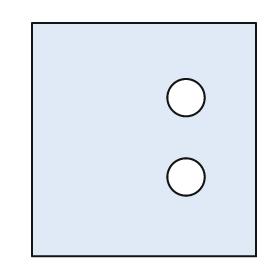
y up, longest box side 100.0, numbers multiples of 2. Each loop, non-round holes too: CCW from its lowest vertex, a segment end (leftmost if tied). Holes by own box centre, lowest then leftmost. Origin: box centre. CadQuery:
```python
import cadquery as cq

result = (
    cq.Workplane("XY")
    .moveTo(-48.0, -50.0)
    .lineTo(48.0, -50.0)
    .lineTo(48.0, 50.0)
    .lineTo(-48.0, 50.0)
    .close()
    .moveTo(18.0, -16.0)
    .circle(8.0)
    .moveTo(18.0, 18.0)
    .circle(8.0)
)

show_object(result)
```